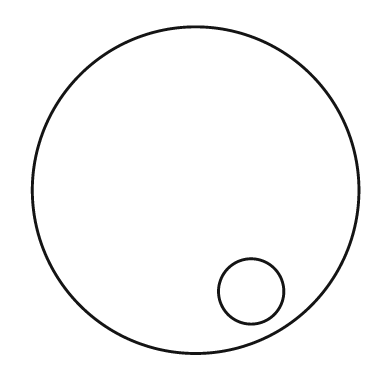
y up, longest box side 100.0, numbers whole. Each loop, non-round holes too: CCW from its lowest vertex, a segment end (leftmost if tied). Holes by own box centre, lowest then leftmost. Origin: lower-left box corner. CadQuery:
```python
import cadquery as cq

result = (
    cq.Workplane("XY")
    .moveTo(50.0, 50.0)
    .circle(50.0)
    .moveTo(67.0, 19.0)
    .circle(10.0)
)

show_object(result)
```